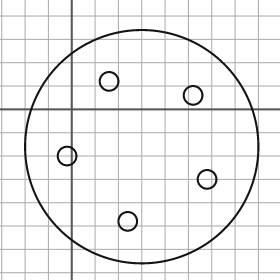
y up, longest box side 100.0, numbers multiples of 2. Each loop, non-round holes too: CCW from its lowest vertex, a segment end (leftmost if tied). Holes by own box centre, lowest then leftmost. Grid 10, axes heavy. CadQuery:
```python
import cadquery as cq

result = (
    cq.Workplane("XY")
    .moveTo(30.0, -16.0)
    .circle(50.0)
    .moveTo(24.0, -48.0)
    .circle(4.0)
    .moveTo(58.0, -30.0)
    .circle(4.0)
    .moveTo(-2.0, -20.0)
    .circle(4.0)
    .moveTo(52.0, 6.0)
    .circle(4.0)
    .moveTo(16.0, 12.0)
    .circle(4.0)
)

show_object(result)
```